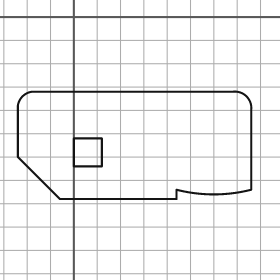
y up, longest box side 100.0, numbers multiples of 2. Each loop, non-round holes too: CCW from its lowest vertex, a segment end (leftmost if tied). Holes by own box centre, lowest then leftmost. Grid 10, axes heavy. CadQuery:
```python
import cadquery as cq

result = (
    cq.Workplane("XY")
    .moveTo(-6.0, -78.0)
    .lineTo(44.0, -78.0)
    .lineTo(44.0, -74.0)
    .threePointArc((60.0, -76.0), (76.0, -74.0))
    .lineTo(76.0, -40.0)
    .threePointArc((74.0, -34.0), (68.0, -32.0))
    .lineTo(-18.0, -32.0)
    .threePointArc((-22.0, -34.0), (-24.0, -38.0))
    .lineTo(-24.0, -60.0)
    .close()
    .moveTo(0.0, -64.0)
    .lineTo(12.0, -64.0)
    .lineTo(12.0, -52.0)
    .lineTo(0.0, -52.0)
    .close()
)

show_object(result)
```